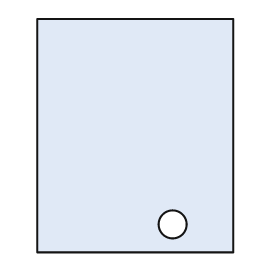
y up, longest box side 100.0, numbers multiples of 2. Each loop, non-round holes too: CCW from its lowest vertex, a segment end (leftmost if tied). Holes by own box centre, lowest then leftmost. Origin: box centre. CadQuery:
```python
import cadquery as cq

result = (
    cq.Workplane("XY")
    .moveTo(-42.0, -50.0)
    .lineTo(42.0, -50.0)
    .lineTo(42.0, 50.0)
    .lineTo(-42.0, 50.0)
    .close()
    .moveTo(16.0, -38.0)
    .circle(6.0)
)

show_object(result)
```